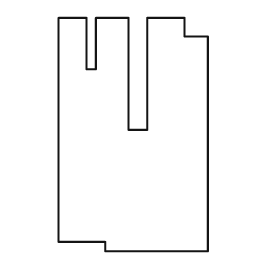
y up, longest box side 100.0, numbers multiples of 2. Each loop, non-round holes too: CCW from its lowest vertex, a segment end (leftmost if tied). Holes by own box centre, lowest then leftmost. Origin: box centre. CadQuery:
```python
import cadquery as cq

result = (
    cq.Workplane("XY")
    .moveTo(-12.0, -50.0)
    .lineTo(32.0, -50.0)
    .lineTo(32.0, 42.0)
    .lineTo(22.0, 42.0)
    .lineTo(22.0, 50.0)
    .lineTo(6.0, 50.0)
    .lineTo(6.0, 2.0)
    .lineTo(-2.0, 2.0)
    .lineTo(-2.0, 50.0)
    .lineTo(-16.0, 50.0)
    .lineTo(-16.0, 28.0)
    .lineTo(-20.0, 28.0)
    .lineTo(-20.0, 50.0)
    .lineTo(-32.0, 50.0)
    .lineTo(-32.0, -46.0)
    .lineTo(-12.0, -46.0)
    .close()
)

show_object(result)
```